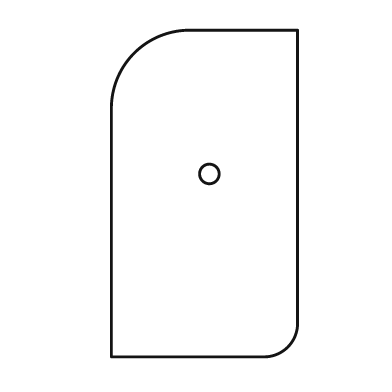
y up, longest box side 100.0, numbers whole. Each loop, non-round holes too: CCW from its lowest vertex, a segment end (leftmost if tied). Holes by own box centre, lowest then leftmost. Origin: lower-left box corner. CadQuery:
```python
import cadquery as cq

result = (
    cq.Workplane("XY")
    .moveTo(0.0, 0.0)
    .lineTo(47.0, 0.0)
    .threePointArc((54.0, 3.0), (57.0, 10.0))
    .lineTo(57.0, 100.0)
    .lineTo(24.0, 100.0)
    .threePointArc((7.0, 93.0), (0.0, 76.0))
    .close()
    .moveTo(30.0, 56.0)
    .circle(3.0)
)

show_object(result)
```